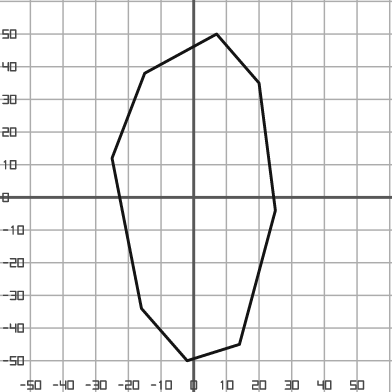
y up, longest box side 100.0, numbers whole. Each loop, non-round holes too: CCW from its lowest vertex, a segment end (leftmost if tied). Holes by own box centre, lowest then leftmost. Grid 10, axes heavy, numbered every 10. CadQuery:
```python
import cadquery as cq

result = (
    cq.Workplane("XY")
    .moveTo(-2.0, -50.0)
    .lineTo(14.0, -45.0)
    .lineTo(25.0, -4.0)
    .lineTo(20.0, 35.0)
    .lineTo(7.0, 50.0)
    .lineTo(-15.0, 38.0)
    .lineTo(-25.0, 12.0)
    .lineTo(-16.0, -34.0)
    .close()
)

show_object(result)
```